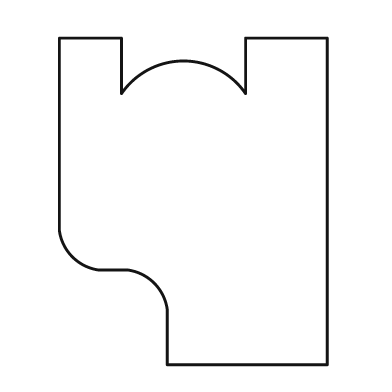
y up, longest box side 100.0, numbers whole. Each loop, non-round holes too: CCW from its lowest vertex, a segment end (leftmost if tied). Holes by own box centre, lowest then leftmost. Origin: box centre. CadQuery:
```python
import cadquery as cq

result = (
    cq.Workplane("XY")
    .moveTo(-8.0, -50.0)
    .lineTo(41.0, -50.0)
    .lineTo(41.0, 50.0)
    .lineTo(16.0, 50.0)
    .lineTo(16.0, 33.0)
    .threePointArc((-3.0, 43.0), (-22.0, 33.0))
    .lineTo(-22.0, 50.0)
    .lineTo(-41.0, 50.0)
    .lineTo(-41.0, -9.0)
    .threePointArc((-37.0, -17.0), (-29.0, -21.0))
    .lineTo(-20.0, -21.0)
    .threePointArc((-12.0, -25.0), (-8.0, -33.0))
    .close()
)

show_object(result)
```